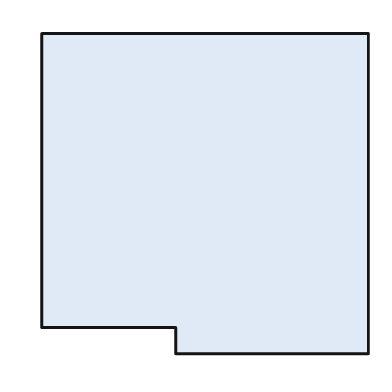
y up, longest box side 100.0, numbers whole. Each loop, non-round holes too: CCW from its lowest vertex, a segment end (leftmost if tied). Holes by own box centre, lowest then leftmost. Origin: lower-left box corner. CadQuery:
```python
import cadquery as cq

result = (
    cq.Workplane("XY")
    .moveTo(41.0, 0.0)
    .lineTo(100.0, 0.0)
    .lineTo(100.0, 98.0)
    .lineTo(0.0, 98.0)
    .lineTo(0.0, 8.0)
    .lineTo(41.0, 8.0)
    .close()
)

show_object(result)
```